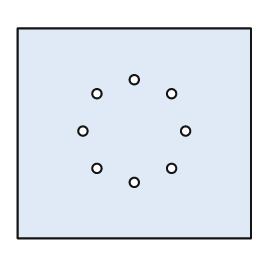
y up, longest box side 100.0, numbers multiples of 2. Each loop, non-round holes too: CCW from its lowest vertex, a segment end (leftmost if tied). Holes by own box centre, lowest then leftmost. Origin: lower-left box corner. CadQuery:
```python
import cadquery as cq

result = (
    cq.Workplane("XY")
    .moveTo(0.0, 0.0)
    .lineTo(100.0, 0.0)
    .lineTo(100.0, 90.0)
    .lineTo(0.0, 90.0)
    .close()
    .moveTo(50.0, 24.0)
    .circle(2.0)
    .moveTo(34.0, 30.0)
    .circle(2.0)
    .moveTo(66.0, 30.0)
    .circle(2.0)
    .moveTo(28.0, 46.0)
    .circle(2.0)
    .moveTo(72.0, 46.0)
    .circle(2.0)
    .moveTo(34.0, 62.0)
    .circle(2.0)
    .moveTo(66.0, 62.0)
    .circle(2.0)
    .moveTo(50.0, 68.0)
    .circle(2.0)
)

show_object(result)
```